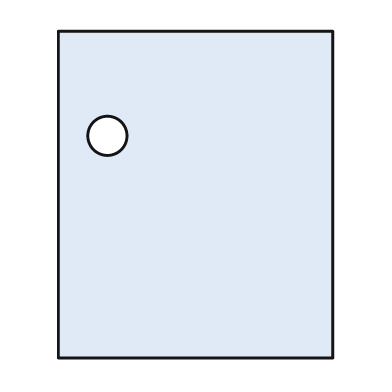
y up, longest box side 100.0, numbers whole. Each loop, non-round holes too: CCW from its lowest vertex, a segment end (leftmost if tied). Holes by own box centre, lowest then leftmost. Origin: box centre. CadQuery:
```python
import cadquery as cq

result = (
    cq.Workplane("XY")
    .moveTo(-42.0, -50.0)
    .lineTo(42.0, -50.0)
    .lineTo(42.0, 50.0)
    .lineTo(-42.0, 50.0)
    .close()
    .moveTo(-27.0, 18.0)
    .circle(6.0)
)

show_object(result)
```